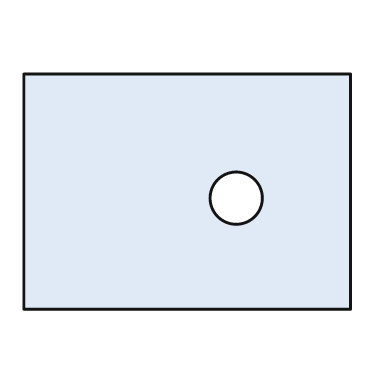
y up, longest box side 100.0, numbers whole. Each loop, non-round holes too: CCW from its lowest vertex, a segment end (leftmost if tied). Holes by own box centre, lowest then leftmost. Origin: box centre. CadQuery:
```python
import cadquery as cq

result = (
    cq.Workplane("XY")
    .moveTo(-50.0, -36.0)
    .lineTo(50.0, -36.0)
    .lineTo(50.0, 36.0)
    .lineTo(-50.0, 36.0)
    .close()
    .moveTo(15.0, -2.0)
    .circle(8.0)
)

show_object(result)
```